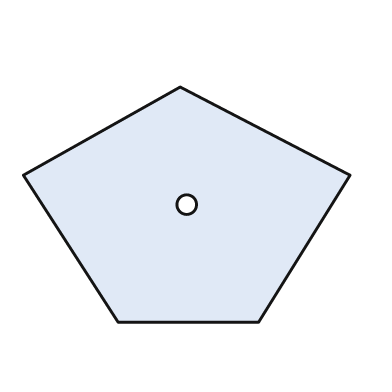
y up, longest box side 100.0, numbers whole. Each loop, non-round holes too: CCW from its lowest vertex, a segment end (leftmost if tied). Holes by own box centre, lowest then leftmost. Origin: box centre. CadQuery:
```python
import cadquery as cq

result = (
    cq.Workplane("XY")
    .moveTo(-21.0, -36.0)
    .lineTo(22.0, -36.0)
    .lineTo(50.0, 9.0)
    .lineTo(-2.0, 36.0)
    .lineTo(-50.0, 9.0)
    .close()
    .moveTo(0.0, 0.0)
    .circle(3.0)
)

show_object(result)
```